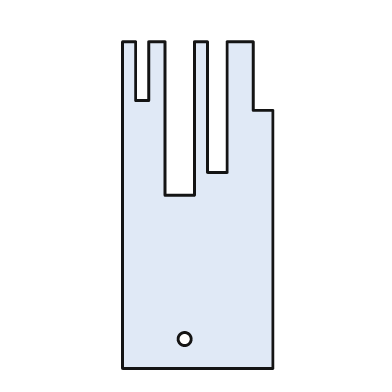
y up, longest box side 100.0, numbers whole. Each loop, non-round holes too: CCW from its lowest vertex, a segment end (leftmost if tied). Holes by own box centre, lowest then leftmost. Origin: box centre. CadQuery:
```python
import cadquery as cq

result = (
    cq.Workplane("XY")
    .moveTo(-23.0, -50.0)
    .lineTo(23.0, -50.0)
    .lineTo(23.0, 29.0)
    .lineTo(17.0, 29.0)
    .lineTo(17.0, 50.0)
    .lineTo(9.0, 50.0)
    .lineTo(9.0, 10.0)
    .lineTo(3.0, 10.0)
    .lineTo(3.0, 50.0)
    .lineTo(-1.0, 50.0)
    .lineTo(-1.0, 3.0)
    .lineTo(-10.0, 3.0)
    .lineTo(-10.0, 50.0)
    .lineTo(-15.0, 50.0)
    .lineTo(-15.0, 32.0)
    .lineTo(-19.0, 32.0)
    .lineTo(-19.0, 50.0)
    .lineTo(-23.0, 50.0)
    .close()
    .moveTo(-4.0, -41.0)
    .circle(2.0)
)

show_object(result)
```